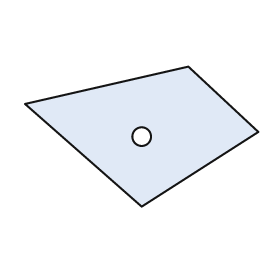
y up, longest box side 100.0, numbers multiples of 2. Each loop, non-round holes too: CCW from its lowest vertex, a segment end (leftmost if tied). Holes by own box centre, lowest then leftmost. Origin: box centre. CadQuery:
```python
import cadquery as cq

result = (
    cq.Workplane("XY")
    .moveTo(0.0, -30.0)
    .lineTo(50.0, 2.0)
    .lineTo(20.0, 30.0)
    .lineTo(-50.0, 14.0)
    .close()
    .moveTo(0.0, 0.0)
    .circle(4.0)
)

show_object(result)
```